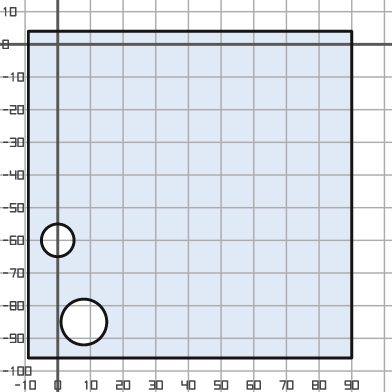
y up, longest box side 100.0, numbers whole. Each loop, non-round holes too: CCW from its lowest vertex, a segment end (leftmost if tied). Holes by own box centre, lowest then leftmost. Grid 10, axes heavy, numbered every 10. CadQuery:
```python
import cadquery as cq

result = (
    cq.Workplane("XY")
    .moveTo(-9.0, -96.0)
    .lineTo(90.0, -96.0)
    .lineTo(90.0, 4.0)
    .lineTo(-9.0, 4.0)
    .close()
    .moveTo(8.0, -85.0)
    .circle(7.0)
    .moveTo(0.0, -60.0)
    .circle(5.0)
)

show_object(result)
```